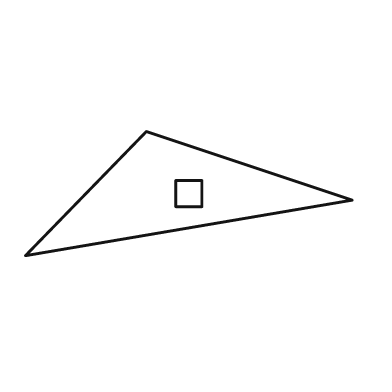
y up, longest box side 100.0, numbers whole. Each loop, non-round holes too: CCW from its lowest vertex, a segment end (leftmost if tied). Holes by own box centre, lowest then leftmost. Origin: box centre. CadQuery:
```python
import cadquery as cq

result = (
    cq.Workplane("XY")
    .moveTo(-50.0, -19.0)
    .lineTo(50.0, -2.0)
    .lineTo(-13.0, 19.0)
    .close()
    .moveTo(-4.0, -4.0)
    .lineTo(4.0, -4.0)
    .lineTo(4.0, 4.0)
    .lineTo(-4.0, 4.0)
    .close()
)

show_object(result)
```